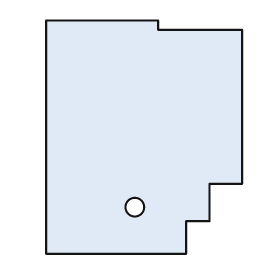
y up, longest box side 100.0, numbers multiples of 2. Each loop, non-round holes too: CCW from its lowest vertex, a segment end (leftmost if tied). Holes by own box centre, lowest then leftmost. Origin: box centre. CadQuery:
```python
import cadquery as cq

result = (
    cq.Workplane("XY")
    .moveTo(-42.0, -50.0)
    .lineTo(18.0, -50.0)
    .lineTo(18.0, -36.0)
    .lineTo(28.0, -36.0)
    .lineTo(28.0, -20.0)
    .lineTo(42.0, -20.0)
    .lineTo(42.0, 46.0)
    .lineTo(6.0, 46.0)
    .lineTo(6.0, 50.0)
    .lineTo(-42.0, 50.0)
    .close()
    .moveTo(-4.0, -30.0)
    .circle(4.0)
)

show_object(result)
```